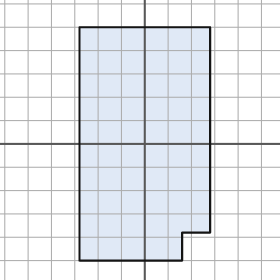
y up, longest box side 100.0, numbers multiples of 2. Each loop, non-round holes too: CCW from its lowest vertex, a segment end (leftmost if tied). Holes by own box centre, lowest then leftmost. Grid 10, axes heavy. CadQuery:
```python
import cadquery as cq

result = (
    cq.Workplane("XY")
    .moveTo(-28.0, -50.0)
    .lineTo(16.0, -50.0)
    .lineTo(16.0, -38.0)
    .lineTo(28.0, -38.0)
    .lineTo(28.0, 50.0)
    .lineTo(-28.0, 50.0)
    .close()
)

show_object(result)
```